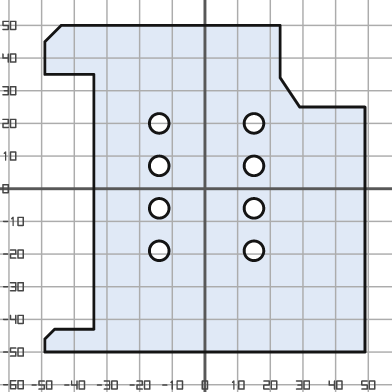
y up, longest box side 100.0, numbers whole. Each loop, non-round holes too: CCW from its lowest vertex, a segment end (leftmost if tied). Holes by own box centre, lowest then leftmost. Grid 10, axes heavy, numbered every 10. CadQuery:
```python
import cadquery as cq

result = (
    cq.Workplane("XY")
    .moveTo(-49.0, -50.0)
    .lineTo(49.0, -50.0)
    .lineTo(49.0, 25.0)
    .lineTo(29.0, 25.0)
    .lineTo(23.0, 34.0)
    .lineTo(23.0, 50.0)
    .lineTo(-44.0, 50.0)
    .lineTo(-49.0, 45.0)
    .lineTo(-49.0, 35.0)
    .lineTo(-34.0, 35.0)
    .lineTo(-34.0, -43.0)
    .lineTo(-46.0, -43.0)
    .lineTo(-49.0, -46.0)
    .close()
    .moveTo(-14.0, -19.0)
    .circle(3.0)
    .moveTo(15.0, -19.0)
    .circle(3.0)
    .moveTo(-14.0, -6.0)
    .circle(3.0)
    .moveTo(15.0, -6.0)
    .circle(3.0)
    .moveTo(-14.0, 7.0)
    .circle(3.0)
    .moveTo(15.0, 7.0)
    .circle(3.0)
    .moveTo(-14.0, 20.0)
    .circle(3.0)
    .moveTo(15.0, 20.0)
    .circle(3.0)
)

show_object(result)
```